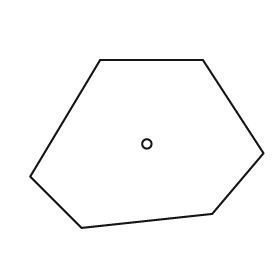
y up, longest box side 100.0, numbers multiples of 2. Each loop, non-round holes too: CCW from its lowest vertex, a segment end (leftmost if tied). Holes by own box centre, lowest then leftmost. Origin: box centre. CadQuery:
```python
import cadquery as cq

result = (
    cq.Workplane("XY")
    .moveTo(-28.0, -36.0)
    .lineTo(28.0, -30.0)
    .lineTo(50.0, -4.0)
    .lineTo(24.0, 36.0)
    .lineTo(-20.0, 36.0)
    .lineTo(-50.0, -14.0)
    .close()
    .moveTo(0.0, 0.0)
    .circle(2.0)
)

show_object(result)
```